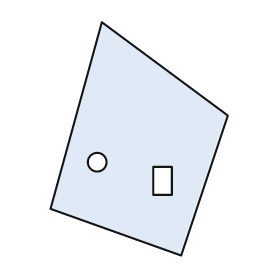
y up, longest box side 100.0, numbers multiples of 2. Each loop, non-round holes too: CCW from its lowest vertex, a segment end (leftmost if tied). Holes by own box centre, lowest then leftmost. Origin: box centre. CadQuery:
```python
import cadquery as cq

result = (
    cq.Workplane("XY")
    .moveTo(18.0, -50.0)
    .lineTo(38.0, 10.0)
    .lineTo(-16.0, 50.0)
    .lineTo(-38.0, -30.0)
    .close()
    .moveTo(6.0, -24.0)
    .lineTo(14.0, -24.0)
    .lineTo(14.0, -12.0)
    .lineTo(6.0, -12.0)
    .close()
    .moveTo(-18.0, -10.0)
    .circle(4.0)
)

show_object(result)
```